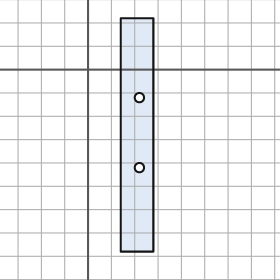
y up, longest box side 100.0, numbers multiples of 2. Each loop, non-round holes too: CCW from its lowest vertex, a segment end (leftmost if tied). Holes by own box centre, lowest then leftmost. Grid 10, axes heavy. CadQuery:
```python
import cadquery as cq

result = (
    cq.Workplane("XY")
    .moveTo(14.0, -78.0)
    .lineTo(28.0, -78.0)
    .lineTo(28.0, 22.0)
    .lineTo(14.0, 22.0)
    .close()
    .moveTo(22.0, -42.0)
    .circle(2.0)
    .moveTo(22.0, -12.0)
    .circle(2.0)
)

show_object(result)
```